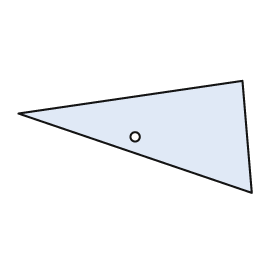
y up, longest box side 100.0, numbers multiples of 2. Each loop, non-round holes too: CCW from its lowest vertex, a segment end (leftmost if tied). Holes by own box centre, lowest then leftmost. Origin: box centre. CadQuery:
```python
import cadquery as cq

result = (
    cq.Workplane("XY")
    .moveTo(50.0, -24.0)
    .lineTo(46.0, 24.0)
    .lineTo(-50.0, 10.0)
    .close()
    .moveTo(0.0, 0.0)
    .circle(2.0)
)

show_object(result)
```